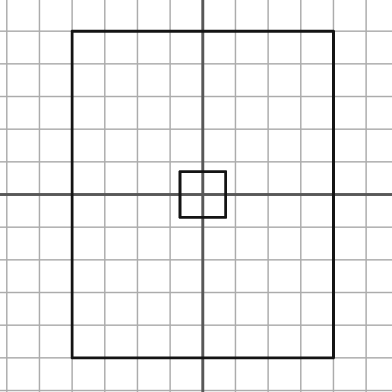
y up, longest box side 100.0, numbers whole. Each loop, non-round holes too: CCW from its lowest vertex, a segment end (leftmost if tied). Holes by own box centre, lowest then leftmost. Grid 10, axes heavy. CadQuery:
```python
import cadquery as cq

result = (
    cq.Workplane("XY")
    .moveTo(-40.0, -50.0)
    .lineTo(40.0, -50.0)
    .lineTo(40.0, 50.0)
    .lineTo(-40.0, 50.0)
    .close()
    .moveTo(-7.0, -7.0)
    .lineTo(7.0, -7.0)
    .lineTo(7.0, 7.0)
    .lineTo(-7.0, 7.0)
    .close()
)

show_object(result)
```